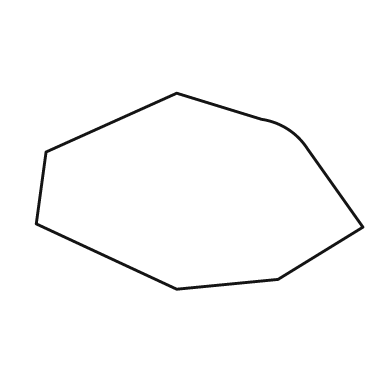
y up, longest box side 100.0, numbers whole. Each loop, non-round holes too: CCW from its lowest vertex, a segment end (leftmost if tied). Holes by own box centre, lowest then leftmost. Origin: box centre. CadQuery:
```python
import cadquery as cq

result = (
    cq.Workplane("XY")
    .moveTo(-7.0, -30.0)
    .lineTo(24.0, -27.0)
    .lineTo(50.0, -11.0)
    .lineTo(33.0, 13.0)
    .threePointArc((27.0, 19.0), (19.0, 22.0))
    .lineTo(-7.0, 30.0)
    .lineTo(-47.0, 12.0)
    .lineTo(-50.0, -10.0)
    .close()
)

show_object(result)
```